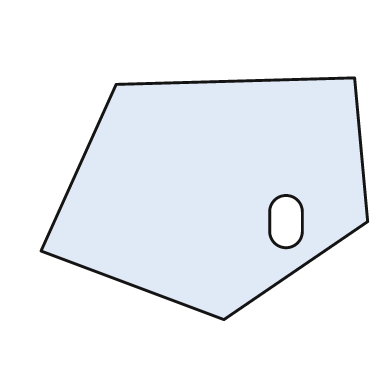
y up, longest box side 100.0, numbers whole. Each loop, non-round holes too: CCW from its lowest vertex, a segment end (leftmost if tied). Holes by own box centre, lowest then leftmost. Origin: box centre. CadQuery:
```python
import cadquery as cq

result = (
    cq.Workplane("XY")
    .moveTo(6.0, -37.0)
    .lineTo(50.0, -7.0)
    .lineTo(46.0, 37.0)
    .lineTo(-27.0, 35.0)
    .lineTo(-50.0, -16.0)
    .close()
    .moveTo(20.0, -10.0)
    .threePointArc((25.0, -15.0), (30.0, -10.0))
    .lineTo(30.0, -4.0)
    .threePointArc((25.0, 1.0), (20.0, -4.0))
    .close()
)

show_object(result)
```